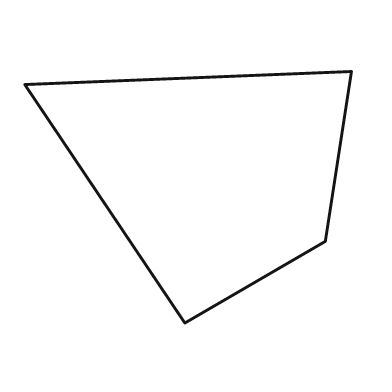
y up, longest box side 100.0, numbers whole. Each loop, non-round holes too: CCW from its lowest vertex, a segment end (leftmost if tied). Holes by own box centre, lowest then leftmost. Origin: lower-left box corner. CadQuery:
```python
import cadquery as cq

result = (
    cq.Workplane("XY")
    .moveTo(49.0, 0.0)
    .lineTo(92.0, 25.0)
    .lineTo(100.0, 77.0)
    .lineTo(0.0, 73.0)
    .close()
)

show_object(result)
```